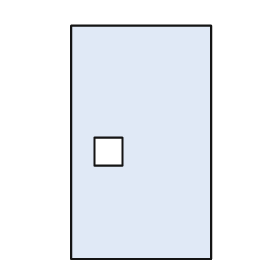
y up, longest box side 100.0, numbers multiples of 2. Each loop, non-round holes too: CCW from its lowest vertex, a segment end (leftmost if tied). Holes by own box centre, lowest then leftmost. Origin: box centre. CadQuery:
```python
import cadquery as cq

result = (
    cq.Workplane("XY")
    .moveTo(-30.0, -50.0)
    .lineTo(30.0, -50.0)
    .lineTo(30.0, 50.0)
    .lineTo(-30.0, 50.0)
    .close()
    .moveTo(-20.0, -10.0)
    .lineTo(-8.0, -10.0)
    .lineTo(-8.0, 2.0)
    .lineTo(-20.0, 2.0)
    .close()
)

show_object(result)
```